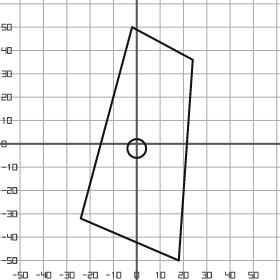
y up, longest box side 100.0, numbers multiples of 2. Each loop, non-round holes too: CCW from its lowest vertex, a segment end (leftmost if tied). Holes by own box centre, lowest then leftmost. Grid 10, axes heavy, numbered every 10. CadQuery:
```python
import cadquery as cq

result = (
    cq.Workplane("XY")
    .moveTo(18.0, -50.0)
    .lineTo(24.0, 36.0)
    .lineTo(-2.0, 50.0)
    .lineTo(-24.0, -32.0)
    .close()
    .moveTo(0.0, -2.0)
    .circle(4.0)
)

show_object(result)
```